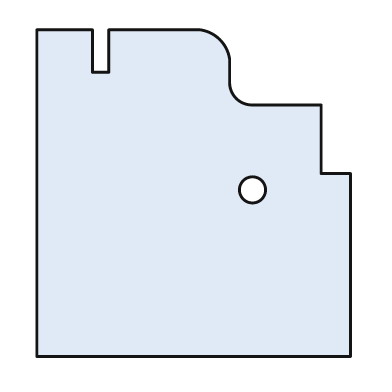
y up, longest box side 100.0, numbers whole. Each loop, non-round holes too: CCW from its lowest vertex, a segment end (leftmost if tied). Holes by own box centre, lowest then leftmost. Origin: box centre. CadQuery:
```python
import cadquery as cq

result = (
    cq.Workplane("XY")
    .moveTo(-48.0, -50.0)
    .lineTo(48.0, -50.0)
    .lineTo(48.0, 6.0)
    .lineTo(39.0, 6.0)
    .lineTo(39.0, 27.0)
    .lineTo(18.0, 27.0)
    .threePointArc((13.0, 29.0), (11.0, 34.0))
    .lineTo(11.0, 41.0)
    .threePointArc((8.0, 47.0), (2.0, 50.0))
    .lineTo(-26.0, 50.0)
    .lineTo(-26.0, 37.0)
    .lineTo(-31.0, 37.0)
    .lineTo(-31.0, 50.0)
    .lineTo(-48.0, 50.0)
    .close()
    .moveTo(18.0, 1.0)
    .circle(4.0)
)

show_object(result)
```